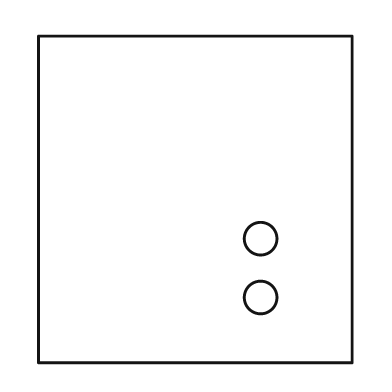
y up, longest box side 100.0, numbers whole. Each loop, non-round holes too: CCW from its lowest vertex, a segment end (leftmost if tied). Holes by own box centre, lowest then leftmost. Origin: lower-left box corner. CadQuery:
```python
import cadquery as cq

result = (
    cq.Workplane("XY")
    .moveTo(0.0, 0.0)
    .lineTo(96.0, 0.0)
    .lineTo(96.0, 100.0)
    .lineTo(0.0, 100.0)
    .close()
    .moveTo(68.0, 20.0)
    .circle(5.0)
    .moveTo(68.0, 38.0)
    .circle(5.0)
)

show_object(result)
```